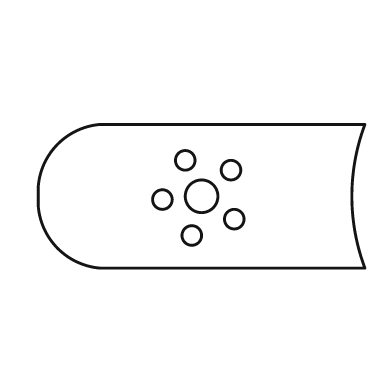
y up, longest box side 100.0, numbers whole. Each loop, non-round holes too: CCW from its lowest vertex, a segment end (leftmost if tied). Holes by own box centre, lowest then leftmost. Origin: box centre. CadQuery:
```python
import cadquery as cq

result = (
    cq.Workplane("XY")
    .moveTo(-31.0, -22.0)
    .lineTo(50.0, -22.0)
    .threePointArc((46.0, 0.0), (50.0, 22.0))
    .lineTo(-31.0, 22.0)
    .threePointArc((-44.0, 16.0), (-50.0, 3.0))
    .lineTo(-50.0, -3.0)
    .threePointArc((-44.0, -16.0), (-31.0, -22.0))
    .close()
    .moveTo(-3.0, -12.0)
    .circle(3.0)
    .moveTo(10.0, -7.0)
    .circle(3.0)
    .moveTo(-12.0, -1.0)
    .circle(3.0)
    .moveTo(0.0, 0.0)
    .circle(5.0)
    .moveTo(9.0, 8.0)
    .circle(3.0)
    .moveTo(-5.0, 11.0)
    .circle(3.0)
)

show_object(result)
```